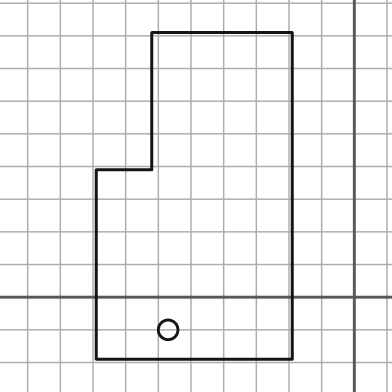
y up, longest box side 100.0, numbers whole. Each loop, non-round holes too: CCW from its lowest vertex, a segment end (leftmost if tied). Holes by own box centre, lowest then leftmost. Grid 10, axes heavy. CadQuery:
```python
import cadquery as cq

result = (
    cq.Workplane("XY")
    .moveTo(-79.0, -19.0)
    .lineTo(-19.0, -19.0)
    .lineTo(-19.0, 81.0)
    .lineTo(-62.0, 81.0)
    .lineTo(-62.0, 39.0)
    .lineTo(-79.0, 39.0)
    .close()
    .moveTo(-57.0, -10.0)
    .circle(3.0)
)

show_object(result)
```